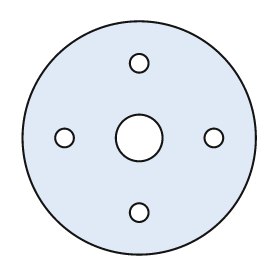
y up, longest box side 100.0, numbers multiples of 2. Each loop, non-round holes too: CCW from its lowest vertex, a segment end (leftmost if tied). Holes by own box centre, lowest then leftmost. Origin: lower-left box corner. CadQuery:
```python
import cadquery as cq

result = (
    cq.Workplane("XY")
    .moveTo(50.0, 50.0)
    .circle(50.0)
    .moveTo(50.0, 18.0)
    .circle(4.0)
    .moveTo(18.0, 50.0)
    .circle(4.0)
    .moveTo(50.0, 50.0)
    .circle(10.0)
    .moveTo(82.0, 50.0)
    .circle(4.0)
    .moveTo(50.0, 82.0)
    .circle(4.0)
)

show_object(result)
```